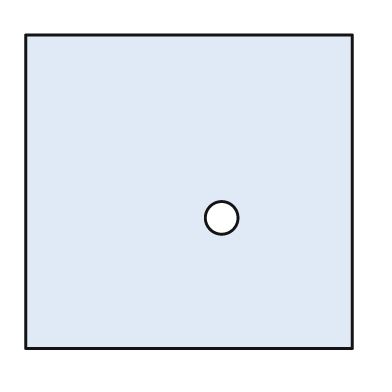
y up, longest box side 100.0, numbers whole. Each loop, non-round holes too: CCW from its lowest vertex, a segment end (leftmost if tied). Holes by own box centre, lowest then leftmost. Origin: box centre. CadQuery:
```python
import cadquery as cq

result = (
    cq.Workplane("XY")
    .moveTo(-50.0, -48.0)
    .lineTo(50.0, -48.0)
    .lineTo(50.0, 48.0)
    .lineTo(-50.0, 48.0)
    .close()
    .moveTo(10.0, -8.0)
    .circle(5.0)
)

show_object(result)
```